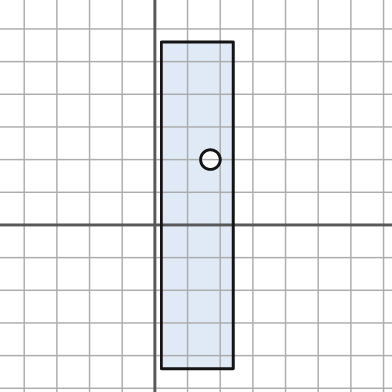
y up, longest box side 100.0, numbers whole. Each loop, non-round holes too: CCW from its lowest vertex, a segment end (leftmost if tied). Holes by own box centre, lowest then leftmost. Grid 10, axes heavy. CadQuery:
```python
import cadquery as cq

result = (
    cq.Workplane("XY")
    .moveTo(2.0, -44.0)
    .lineTo(24.0, -44.0)
    .lineTo(24.0, 56.0)
    .lineTo(2.0, 56.0)
    .close()
    .moveTo(17.0, 20.0)
    .circle(3.0)
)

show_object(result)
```